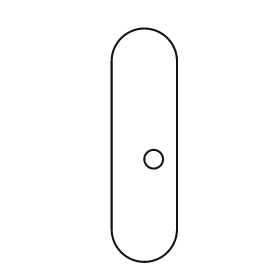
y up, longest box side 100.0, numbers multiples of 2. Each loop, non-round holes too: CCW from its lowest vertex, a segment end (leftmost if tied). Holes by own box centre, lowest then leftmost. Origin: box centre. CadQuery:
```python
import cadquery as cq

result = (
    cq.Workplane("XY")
    .moveTo(-14.0, -36.0)
    .threePointArc((0.0, -50.0), (14.0, -36.0))
    .lineTo(14.0, 36.0)
    .threePointArc((0.0, 50.0), (-14.0, 36.0))
    .close()
    .moveTo(4.0, -6.0)
    .circle(4.0)
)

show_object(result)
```